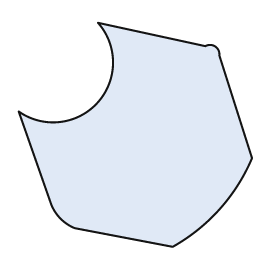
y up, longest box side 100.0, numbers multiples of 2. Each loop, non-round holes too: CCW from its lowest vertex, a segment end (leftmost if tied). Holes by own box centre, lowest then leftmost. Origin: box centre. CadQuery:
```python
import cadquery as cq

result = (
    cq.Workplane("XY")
    .moveTo(16.0, -48.0)
    .threePointArc((36.0, -32.0), (50.0, -10.0))
    .lineTo(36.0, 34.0)
    .threePointArc((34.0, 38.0), (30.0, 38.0))
    .lineTo(-16.0, 48.0)
    .threePointArc((-16.0, 14.0), (-50.0, 10.0))
    .lineTo(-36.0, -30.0)
    .threePointArc((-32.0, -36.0), (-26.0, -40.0))
    .close()
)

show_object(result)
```